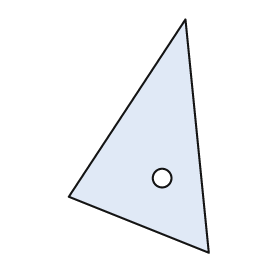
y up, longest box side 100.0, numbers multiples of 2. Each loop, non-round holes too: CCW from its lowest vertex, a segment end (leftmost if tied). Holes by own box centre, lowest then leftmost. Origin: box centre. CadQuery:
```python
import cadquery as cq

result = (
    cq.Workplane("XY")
    .moveTo(30.0, -50.0)
    .lineTo(20.0, 50.0)
    .lineTo(-30.0, -26.0)
    .close()
    .moveTo(10.0, -18.0)
    .circle(4.0)
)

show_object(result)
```